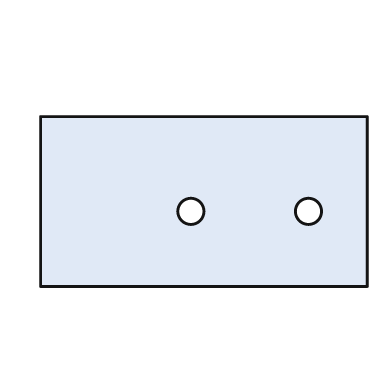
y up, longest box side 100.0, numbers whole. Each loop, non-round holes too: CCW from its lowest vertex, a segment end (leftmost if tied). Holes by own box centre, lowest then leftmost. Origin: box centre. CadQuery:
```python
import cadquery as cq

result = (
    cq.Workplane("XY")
    .moveTo(-50.0, -26.0)
    .lineTo(50.0, -26.0)
    .lineTo(50.0, 26.0)
    .lineTo(-50.0, 26.0)
    .close()
    .moveTo(-4.0, -3.0)
    .circle(4.0)
    .moveTo(32.0, -3.0)
    .circle(4.0)
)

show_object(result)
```